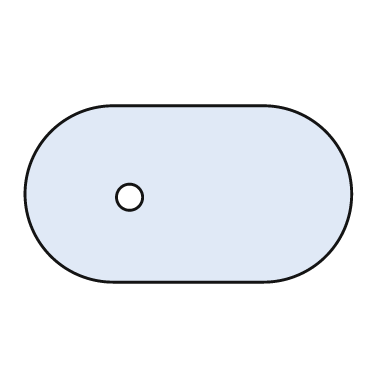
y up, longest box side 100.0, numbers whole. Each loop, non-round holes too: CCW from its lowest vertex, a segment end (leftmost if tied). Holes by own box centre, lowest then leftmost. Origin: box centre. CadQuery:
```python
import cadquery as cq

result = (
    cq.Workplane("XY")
    .moveTo(-23.0, -27.0)
    .lineTo(23.0, -27.0)
    .threePointArc((50.0, 0.0), (23.0, 27.0))
    .lineTo(-23.0, 27.0)
    .threePointArc((-50.0, 0.0), (-23.0, -27.0))
    .close()
    .moveTo(-18.0, -1.0)
    .circle(4.0)
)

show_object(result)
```